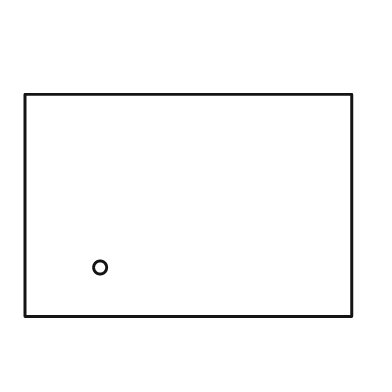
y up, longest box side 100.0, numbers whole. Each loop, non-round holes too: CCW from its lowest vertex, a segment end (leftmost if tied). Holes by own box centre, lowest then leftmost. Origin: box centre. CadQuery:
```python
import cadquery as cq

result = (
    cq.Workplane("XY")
    .moveTo(-50.0, -34.0)
    .lineTo(50.0, -34.0)
    .lineTo(50.0, 34.0)
    .lineTo(-50.0, 34.0)
    .close()
    .moveTo(-27.0, -19.0)
    .circle(2.0)
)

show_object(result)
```